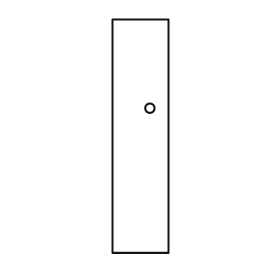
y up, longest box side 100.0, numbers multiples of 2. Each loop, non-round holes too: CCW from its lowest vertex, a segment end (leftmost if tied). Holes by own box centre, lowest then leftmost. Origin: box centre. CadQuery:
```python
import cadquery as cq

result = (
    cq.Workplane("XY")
    .moveTo(-12.0, -50.0)
    .lineTo(12.0, -50.0)
    .lineTo(12.0, 50.0)
    .lineTo(-12.0, 50.0)
    .close()
    .moveTo(4.0, 12.0)
    .circle(2.0)
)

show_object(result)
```